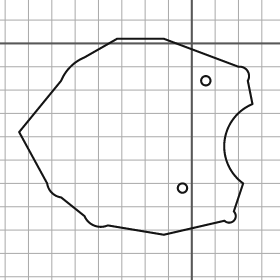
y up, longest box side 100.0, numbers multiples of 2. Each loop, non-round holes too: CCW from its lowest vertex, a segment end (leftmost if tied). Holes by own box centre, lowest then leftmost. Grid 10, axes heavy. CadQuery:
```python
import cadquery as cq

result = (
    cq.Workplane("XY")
    .moveTo(-12.0, -82.0)
    .lineTo(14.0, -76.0)
    .threePointArc((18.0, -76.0), (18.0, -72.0))
    .lineTo(22.0, -60.0)
    .threePointArc((14.0, -42.0), (26.0, -26.0))
    .lineTo(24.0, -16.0)
    .threePointArc((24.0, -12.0), (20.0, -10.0))
    .lineTo(-12.0, 2.0)
    .lineTo(-32.0, 2.0)
    .lineTo(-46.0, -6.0)
    .threePointArc((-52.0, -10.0), (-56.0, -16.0))
    .lineTo(-74.0, -38.0)
    .lineTo(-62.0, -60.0)
    .threePointArc((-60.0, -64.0), (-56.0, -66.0))
    .lineTo(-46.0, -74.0)
    .threePointArc((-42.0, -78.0), (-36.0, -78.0))
    .close()
    .moveTo(-4.0, -62.0)
    .circle(2.0)
    .moveTo(6.0, -16.0)
    .circle(2.0)
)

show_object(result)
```